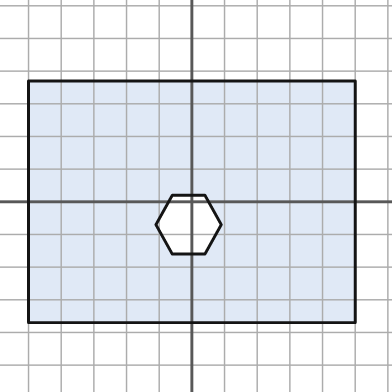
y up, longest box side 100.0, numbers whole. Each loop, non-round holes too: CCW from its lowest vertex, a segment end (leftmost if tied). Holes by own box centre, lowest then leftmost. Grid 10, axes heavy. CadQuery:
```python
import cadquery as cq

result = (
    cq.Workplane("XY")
    .moveTo(-50.0, -37.0)
    .lineTo(50.0, -37.0)
    .lineTo(50.0, 37.0)
    .lineTo(-50.0, 37.0)
    .close()
    .moveTo(-6.0, -16.0)
    .lineTo(4.0, -16.0)
    .lineTo(9.0, -7.0)
    .lineTo(4.0, 2.0)
    .lineTo(-6.0, 2.0)
    .lineTo(-11.0, -7.0)
    .close()
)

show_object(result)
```